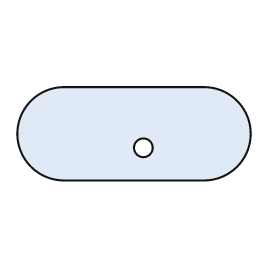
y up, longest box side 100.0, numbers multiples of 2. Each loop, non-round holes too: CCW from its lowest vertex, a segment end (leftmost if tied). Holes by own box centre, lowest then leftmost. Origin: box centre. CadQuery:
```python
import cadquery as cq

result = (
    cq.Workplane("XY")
    .moveTo(-30.0, -20.0)
    .lineTo(30.0, -20.0)
    .threePointArc((50.0, 0.0), (30.0, 20.0))
    .lineTo(-30.0, 20.0)
    .threePointArc((-50.0, 0.0), (-30.0, -20.0))
    .close()
    .moveTo(4.0, -6.0)
    .circle(4.0)
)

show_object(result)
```